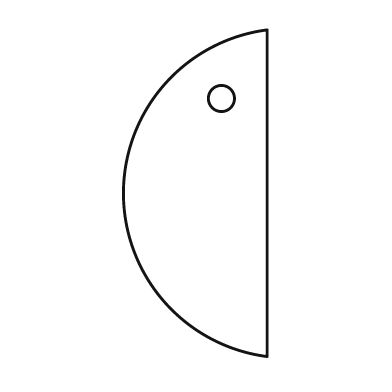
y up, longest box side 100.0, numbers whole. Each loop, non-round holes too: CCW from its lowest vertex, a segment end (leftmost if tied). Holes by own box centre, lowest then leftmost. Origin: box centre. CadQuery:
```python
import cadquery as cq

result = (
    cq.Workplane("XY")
    .moveTo(22.0, -50.0)
    .lineTo(22.0, 50.0)
    .threePointArc((-22.0, 0.0), (22.0, -50.0))
    .close()
    .moveTo(8.0, 29.0)
    .circle(4.0)
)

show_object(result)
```